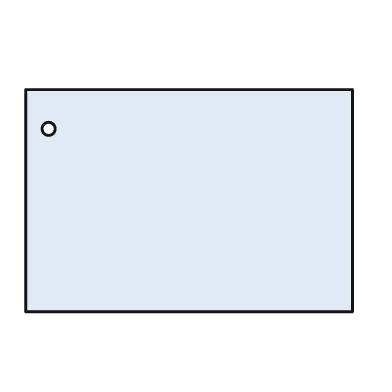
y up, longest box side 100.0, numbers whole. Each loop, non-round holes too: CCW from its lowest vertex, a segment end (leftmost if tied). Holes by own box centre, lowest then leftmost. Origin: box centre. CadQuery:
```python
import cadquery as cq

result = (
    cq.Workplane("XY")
    .moveTo(-50.0, -34.0)
    .lineTo(50.0, -34.0)
    .lineTo(50.0, 34.0)
    .lineTo(-50.0, 34.0)
    .close()
    .moveTo(-43.0, 22.0)
    .circle(2.0)
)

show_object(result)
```